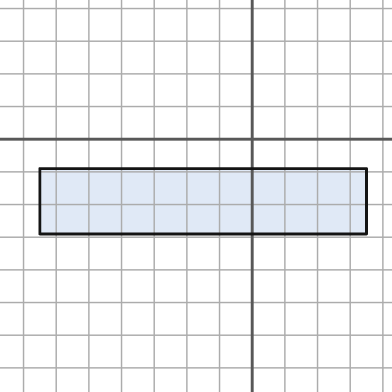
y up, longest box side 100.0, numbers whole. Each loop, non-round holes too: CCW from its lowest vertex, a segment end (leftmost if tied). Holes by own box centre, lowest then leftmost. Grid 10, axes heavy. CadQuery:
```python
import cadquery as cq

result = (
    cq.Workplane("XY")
    .moveTo(-65.0, -29.0)
    .lineTo(35.0, -29.0)
    .lineTo(35.0, -9.0)
    .lineTo(-65.0, -9.0)
    .close()
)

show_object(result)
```